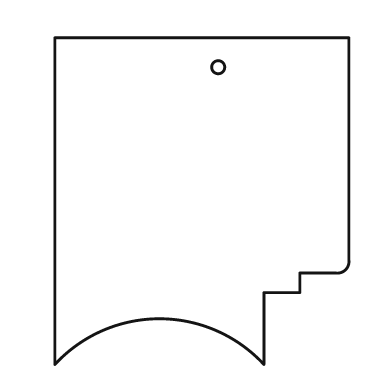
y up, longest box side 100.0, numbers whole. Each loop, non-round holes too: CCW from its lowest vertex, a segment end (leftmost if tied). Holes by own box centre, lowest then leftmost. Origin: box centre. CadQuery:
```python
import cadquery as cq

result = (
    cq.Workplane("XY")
    .moveTo(-45.0, -50.0)
    .threePointArc((-13.0, -36.0), (19.0, -50.0))
    .lineTo(19.0, -28.0)
    .lineTo(30.0, -28.0)
    .lineTo(30.0, -22.0)
    .lineTo(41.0, -22.0)
    .threePointArc((44.0, -21.0), (45.0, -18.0))
    .lineTo(45.0, 50.0)
    .lineTo(-45.0, 50.0)
    .close()
    .moveTo(5.0, 41.0)
    .circle(2.0)
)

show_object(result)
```